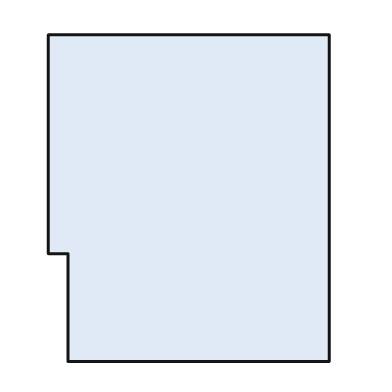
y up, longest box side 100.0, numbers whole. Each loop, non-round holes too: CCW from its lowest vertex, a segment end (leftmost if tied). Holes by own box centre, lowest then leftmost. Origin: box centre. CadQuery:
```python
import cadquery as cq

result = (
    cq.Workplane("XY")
    .moveTo(-37.0, -50.0)
    .lineTo(43.0, -50.0)
    .lineTo(43.0, 50.0)
    .lineTo(-43.0, 50.0)
    .lineTo(-43.0, -17.0)
    .lineTo(-37.0, -17.0)
    .close()
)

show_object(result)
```